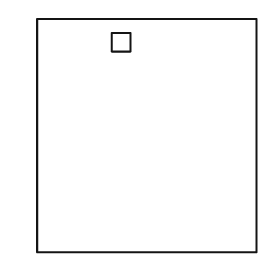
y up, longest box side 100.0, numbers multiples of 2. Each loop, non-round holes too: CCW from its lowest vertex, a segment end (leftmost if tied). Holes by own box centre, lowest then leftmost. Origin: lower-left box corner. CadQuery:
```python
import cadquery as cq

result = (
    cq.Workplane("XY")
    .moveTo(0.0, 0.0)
    .lineTo(94.0, 0.0)
    .lineTo(94.0, 100.0)
    .lineTo(0.0, 100.0)
    .close()
    .moveTo(32.0, 86.0)
    .lineTo(40.0, 86.0)
    .lineTo(40.0, 94.0)
    .lineTo(32.0, 94.0)
    .close()
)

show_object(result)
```